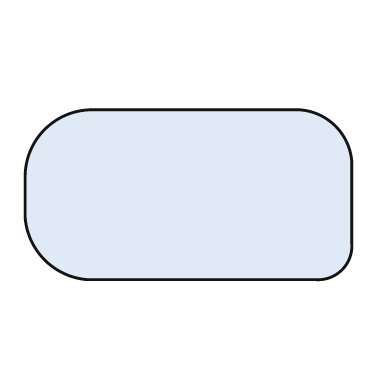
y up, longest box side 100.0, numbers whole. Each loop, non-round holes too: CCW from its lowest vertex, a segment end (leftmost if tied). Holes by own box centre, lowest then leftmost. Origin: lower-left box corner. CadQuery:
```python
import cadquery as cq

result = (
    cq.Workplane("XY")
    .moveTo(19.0, 0.0)
    .lineTo(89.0, 0.0)
    .threePointArc((97.0, 3.0), (100.0, 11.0))
    .lineTo(100.0, 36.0)
    .threePointArc((95.0, 47.0), (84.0, 52.0))
    .lineTo(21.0, 52.0)
    .threePointArc((6.0, 46.0), (0.0, 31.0))
    .lineTo(0.0, 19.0)
    .threePointArc((6.0, 6.0), (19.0, 0.0))
    .close()
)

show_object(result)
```